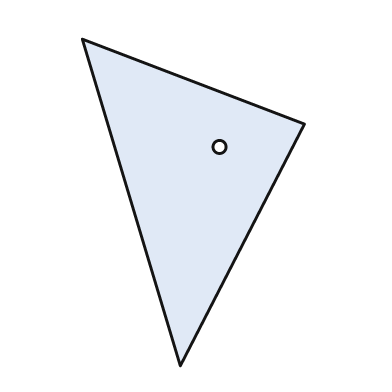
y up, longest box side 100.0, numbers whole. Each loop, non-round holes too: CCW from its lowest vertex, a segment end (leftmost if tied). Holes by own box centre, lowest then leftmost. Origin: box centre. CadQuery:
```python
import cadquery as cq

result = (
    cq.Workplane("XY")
    .moveTo(-4.0, -50.0)
    .lineTo(34.0, 24.0)
    .lineTo(-34.0, 50.0)
    .close()
    .moveTo(8.0, 17.0)
    .circle(2.0)
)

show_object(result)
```